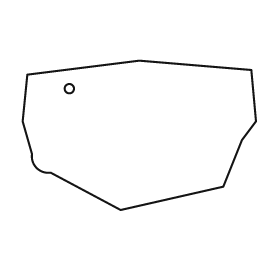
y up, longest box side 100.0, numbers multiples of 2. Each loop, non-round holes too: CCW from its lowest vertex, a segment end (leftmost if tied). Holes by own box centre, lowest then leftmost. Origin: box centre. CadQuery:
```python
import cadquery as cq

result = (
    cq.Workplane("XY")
    .moveTo(-8.0, -32.0)
    .lineTo(36.0, -22.0)
    .lineTo(44.0, -2.0)
    .lineTo(50.0, 6.0)
    .lineTo(48.0, 28.0)
    .lineTo(0.0, 32.0)
    .lineTo(-48.0, 26.0)
    .lineTo(-50.0, 6.0)
    .lineTo(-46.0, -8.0)
    .threePointArc((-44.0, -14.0), (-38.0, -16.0))
    .close()
    .moveTo(-30.0, 20.0)
    .circle(2.0)
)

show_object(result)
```